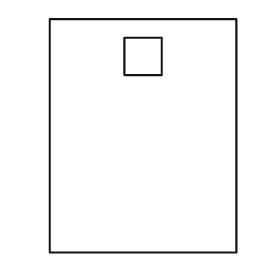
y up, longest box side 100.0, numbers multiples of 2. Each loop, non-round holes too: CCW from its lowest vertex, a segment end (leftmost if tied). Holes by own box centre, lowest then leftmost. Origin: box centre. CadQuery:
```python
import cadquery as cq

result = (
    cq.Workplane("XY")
    .moveTo(-40.0, -50.0)
    .lineTo(40.0, -50.0)
    .lineTo(40.0, 50.0)
    .lineTo(-40.0, 50.0)
    .close()
    .moveTo(-8.0, 26.0)
    .lineTo(8.0, 26.0)
    .lineTo(8.0, 42.0)
    .lineTo(-8.0, 42.0)
    .close()
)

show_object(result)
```